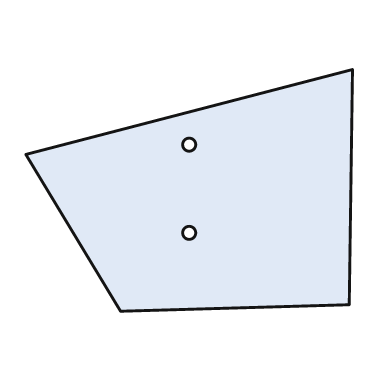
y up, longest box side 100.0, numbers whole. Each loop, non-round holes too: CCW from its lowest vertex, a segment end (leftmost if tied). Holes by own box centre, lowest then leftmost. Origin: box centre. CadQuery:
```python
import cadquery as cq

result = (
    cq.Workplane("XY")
    .moveTo(-21.0, -37.0)
    .lineTo(49.0, -35.0)
    .lineTo(50.0, 37.0)
    .lineTo(-50.0, 11.0)
    .close()
    .moveTo(0.0, -13.0)
    .circle(2.0)
    .moveTo(0.0, 14.0)
    .circle(2.0)
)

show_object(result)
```